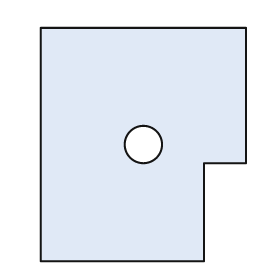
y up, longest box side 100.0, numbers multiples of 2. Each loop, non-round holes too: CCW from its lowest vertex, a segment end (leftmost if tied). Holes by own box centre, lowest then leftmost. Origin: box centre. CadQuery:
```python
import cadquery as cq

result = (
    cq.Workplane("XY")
    .moveTo(-44.0, -50.0)
    .lineTo(26.0, -50.0)
    .lineTo(26.0, -8.0)
    .lineTo(44.0, -8.0)
    .lineTo(44.0, 50.0)
    .lineTo(-44.0, 50.0)
    .close()
    .moveTo(0.0, 0.0)
    .circle(8.0)
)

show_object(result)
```